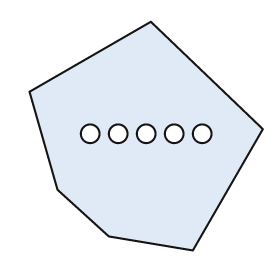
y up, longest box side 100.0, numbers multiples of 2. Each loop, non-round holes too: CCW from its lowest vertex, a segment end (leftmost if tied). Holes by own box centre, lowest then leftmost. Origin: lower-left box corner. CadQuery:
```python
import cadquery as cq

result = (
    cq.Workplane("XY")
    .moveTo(70.0, 0.0)
    .lineTo(100.0, 52.0)
    .lineTo(52.0, 98.0)
    .lineTo(0.0, 68.0)
    .lineTo(12.0, 26.0)
    .lineTo(34.0, 6.0)
    .close()
    .moveTo(26.0, 50.0)
    .circle(4.0)
    .moveTo(38.0, 50.0)
    .circle(4.0)
    .moveTo(50.0, 50.0)
    .circle(4.0)
    .moveTo(62.0, 50.0)
    .circle(4.0)
    .moveTo(74.0, 50.0)
    .circle(4.0)
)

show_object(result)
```